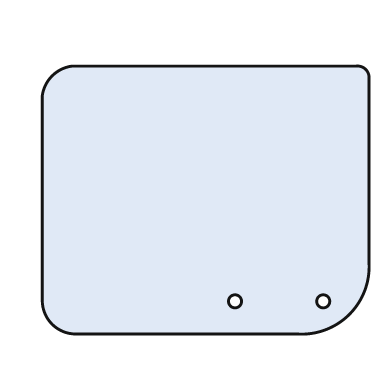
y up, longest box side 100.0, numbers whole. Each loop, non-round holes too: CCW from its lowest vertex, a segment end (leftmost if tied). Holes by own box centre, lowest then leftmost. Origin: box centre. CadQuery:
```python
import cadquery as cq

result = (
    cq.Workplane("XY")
    .moveTo(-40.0, -41.0)
    .lineTo(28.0, -41.0)
    .threePointArc((44.0, -35.0), (50.0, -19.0))
    .lineTo(50.0, 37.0)
    .threePointArc((49.0, 40.0), (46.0, 41.0))
    .lineTo(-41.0, 41.0)
    .threePointArc((-47.0, 38.0), (-50.0, 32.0))
    .lineTo(-50.0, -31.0)
    .threePointArc((-47.0, -38.0), (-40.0, -41.0))
    .close()
    .moveTo(9.0, -31.0)
    .circle(2.0)
    .moveTo(36.0, -31.0)
    .circle(2.0)
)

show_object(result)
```